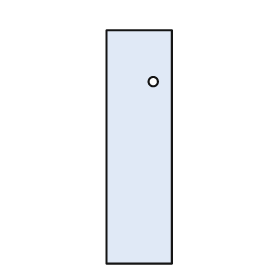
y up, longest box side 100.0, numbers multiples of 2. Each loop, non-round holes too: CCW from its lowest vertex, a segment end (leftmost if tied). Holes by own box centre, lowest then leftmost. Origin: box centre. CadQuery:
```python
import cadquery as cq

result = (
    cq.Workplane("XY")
    .moveTo(-14.0, -50.0)
    .lineTo(14.0, -50.0)
    .lineTo(14.0, 50.0)
    .lineTo(-14.0, 50.0)
    .close()
    .moveTo(6.0, 28.0)
    .circle(2.0)
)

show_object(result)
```